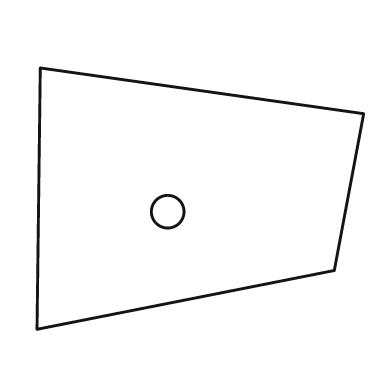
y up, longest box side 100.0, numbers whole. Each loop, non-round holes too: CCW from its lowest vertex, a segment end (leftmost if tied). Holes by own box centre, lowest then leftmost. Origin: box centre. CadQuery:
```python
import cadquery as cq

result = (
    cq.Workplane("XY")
    .moveTo(-50.0, -40.0)
    .lineTo(41.0, -22.0)
    .lineTo(50.0, 26.0)
    .lineTo(-49.0, 40.0)
    .close()
    .moveTo(-10.0, -4.0)
    .circle(5.0)
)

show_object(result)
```